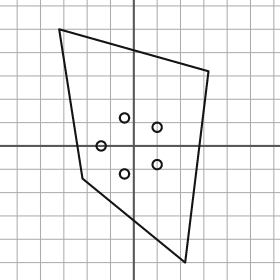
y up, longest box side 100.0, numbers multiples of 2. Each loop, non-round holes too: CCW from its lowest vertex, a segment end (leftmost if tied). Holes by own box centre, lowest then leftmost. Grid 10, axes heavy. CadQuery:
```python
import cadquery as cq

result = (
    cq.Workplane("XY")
    .moveTo(22.0, -50.0)
    .lineTo(32.0, 32.0)
    .lineTo(-32.0, 50.0)
    .lineTo(-22.0, -14.0)
    .close()
    .moveTo(-4.0, -12.0)
    .circle(2.0)
    .moveTo(10.0, -8.0)
    .circle(2.0)
    .moveTo(-14.0, 0.0)
    .circle(2.0)
    .moveTo(10.0, 8.0)
    .circle(2.0)
    .moveTo(-4.0, 12.0)
    .circle(2.0)
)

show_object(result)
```